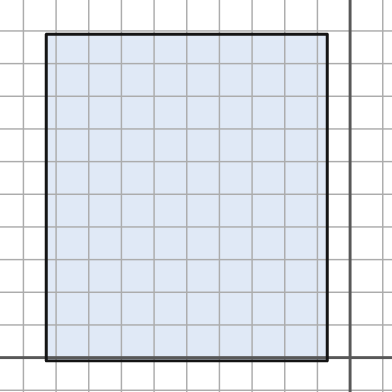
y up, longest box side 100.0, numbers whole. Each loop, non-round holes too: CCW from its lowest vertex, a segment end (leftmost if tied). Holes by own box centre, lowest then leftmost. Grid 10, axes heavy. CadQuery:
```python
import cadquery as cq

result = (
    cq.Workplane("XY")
    .moveTo(-93.0, -1.0)
    .lineTo(-7.0, -1.0)
    .lineTo(-7.0, 99.0)
    .lineTo(-93.0, 99.0)
    .close()
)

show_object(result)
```